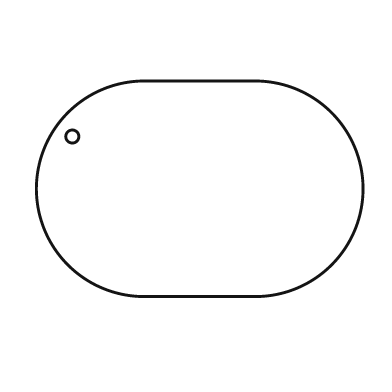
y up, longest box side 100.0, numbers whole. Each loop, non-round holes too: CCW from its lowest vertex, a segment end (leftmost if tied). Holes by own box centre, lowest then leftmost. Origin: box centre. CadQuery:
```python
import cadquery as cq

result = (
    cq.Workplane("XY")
    .moveTo(-17.0, -33.0)
    .lineTo(17.0, -33.0)
    .threePointArc((50.0, 0.0), (17.0, 33.0))
    .lineTo(-17.0, 33.0)
    .threePointArc((-50.0, 0.0), (-17.0, -33.0))
    .close()
    .moveTo(-39.0, 16.0)
    .circle(2.0)
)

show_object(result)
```